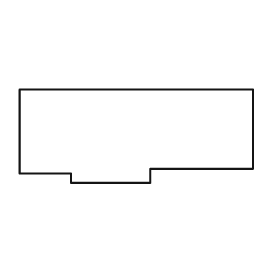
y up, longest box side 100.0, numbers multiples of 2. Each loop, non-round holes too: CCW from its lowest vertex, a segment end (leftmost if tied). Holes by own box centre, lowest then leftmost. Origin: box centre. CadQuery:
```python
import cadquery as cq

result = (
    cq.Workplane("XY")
    .moveTo(-28.0, -20.0)
    .lineTo(6.0, -20.0)
    .lineTo(6.0, -14.0)
    .lineTo(50.0, -14.0)
    .lineTo(50.0, 20.0)
    .lineTo(-50.0, 20.0)
    .lineTo(-50.0, -16.0)
    .lineTo(-28.0, -16.0)
    .close()
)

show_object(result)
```